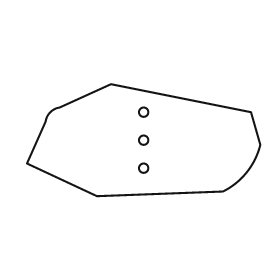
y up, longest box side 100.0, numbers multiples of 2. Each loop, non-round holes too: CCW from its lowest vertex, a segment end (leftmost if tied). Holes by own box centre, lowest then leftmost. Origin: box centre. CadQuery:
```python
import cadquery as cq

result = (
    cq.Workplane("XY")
    .moveTo(-20.0, -24.0)
    .lineTo(34.0, -22.0)
    .threePointArc((44.0, -14.0), (50.0, -2.0))
    .lineTo(46.0, 12.0)
    .lineTo(-14.0, 24.0)
    .lineTo(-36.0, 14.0)
    .threePointArc((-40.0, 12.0), (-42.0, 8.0))
    .lineTo(-50.0, -10.0)
    .close()
    .moveTo(0.0, -12.0)
    .circle(2.0)
    .moveTo(0.0, 0.0)
    .circle(2.0)
    .moveTo(0.0, 12.0)
    .circle(2.0)
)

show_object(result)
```